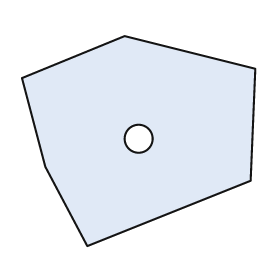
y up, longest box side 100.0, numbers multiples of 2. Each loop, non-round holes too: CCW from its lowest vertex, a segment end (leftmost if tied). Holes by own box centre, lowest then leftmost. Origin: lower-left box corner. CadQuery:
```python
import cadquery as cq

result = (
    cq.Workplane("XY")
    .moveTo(28.0, 0.0)
    .lineTo(98.0, 28.0)
    .lineTo(100.0, 76.0)
    .lineTo(44.0, 90.0)
    .lineTo(0.0, 72.0)
    .lineTo(10.0, 34.0)
    .close()
    .moveTo(50.0, 46.0)
    .circle(6.0)
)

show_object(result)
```